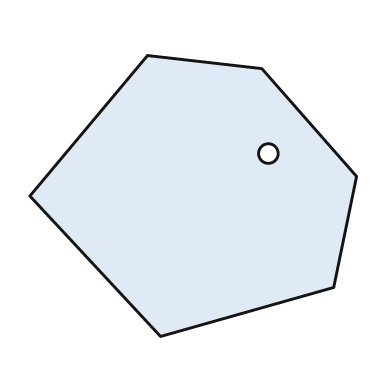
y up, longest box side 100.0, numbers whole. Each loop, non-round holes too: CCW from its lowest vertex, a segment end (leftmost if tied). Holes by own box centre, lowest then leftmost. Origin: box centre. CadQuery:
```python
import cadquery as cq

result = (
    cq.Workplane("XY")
    .moveTo(-10.0, -43.0)
    .lineTo(43.0, -28.0)
    .lineTo(50.0, 6.0)
    .lineTo(21.0, 39.0)
    .lineTo(-14.0, 43.0)
    .lineTo(-50.0, 0.0)
    .close()
    .moveTo(23.0, 13.0)
    .circle(3.0)
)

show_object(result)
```